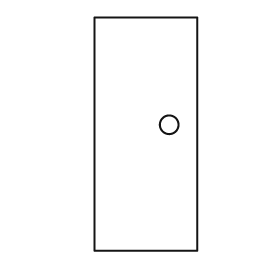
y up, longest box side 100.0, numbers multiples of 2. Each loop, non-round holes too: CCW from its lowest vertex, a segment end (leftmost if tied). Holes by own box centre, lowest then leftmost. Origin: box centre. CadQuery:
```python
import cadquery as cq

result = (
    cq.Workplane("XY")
    .moveTo(-22.0, -50.0)
    .lineTo(22.0, -50.0)
    .lineTo(22.0, 50.0)
    .lineTo(-22.0, 50.0)
    .close()
    .moveTo(10.0, 4.0)
    .circle(4.0)
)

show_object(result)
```